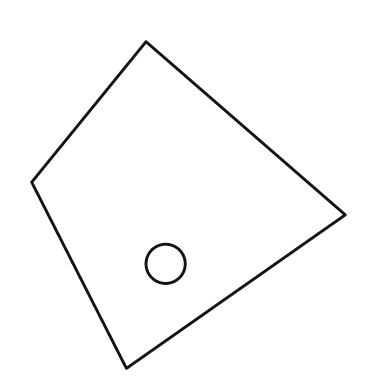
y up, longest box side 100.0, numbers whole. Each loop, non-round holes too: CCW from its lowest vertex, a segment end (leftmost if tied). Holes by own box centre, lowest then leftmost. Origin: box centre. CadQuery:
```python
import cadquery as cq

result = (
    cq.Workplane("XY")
    .moveTo(-19.0, -50.0)
    .lineTo(48.0, -3.0)
    .lineTo(-13.0, 50.0)
    .lineTo(-48.0, 7.0)
    .close()
    .moveTo(-7.0, -18.0)
    .circle(6.0)
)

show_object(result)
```